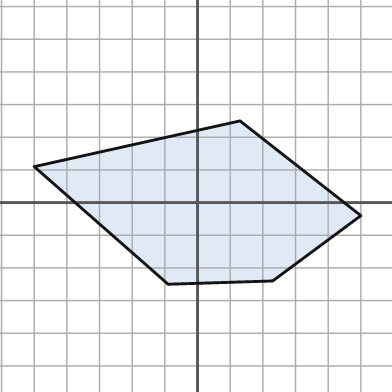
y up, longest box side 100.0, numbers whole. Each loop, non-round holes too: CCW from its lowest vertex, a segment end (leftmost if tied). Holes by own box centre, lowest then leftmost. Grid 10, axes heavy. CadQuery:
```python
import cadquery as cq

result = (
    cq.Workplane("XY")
    .moveTo(-9.0, -25.0)
    .lineTo(23.0, -24.0)
    .lineTo(50.0, -4.0)
    .lineTo(13.0, 25.0)
    .lineTo(-50.0, 11.0)
    .close()
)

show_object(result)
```